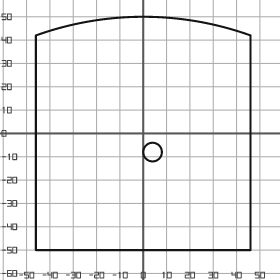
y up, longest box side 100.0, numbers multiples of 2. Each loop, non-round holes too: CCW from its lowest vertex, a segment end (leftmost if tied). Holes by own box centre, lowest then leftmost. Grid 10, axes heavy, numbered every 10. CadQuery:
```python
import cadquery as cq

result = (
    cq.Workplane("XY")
    .moveTo(-46.0, -50.0)
    .lineTo(46.0, -50.0)
    .lineTo(46.0, 42.0)
    .threePointArc((0.0, 50.0), (-46.0, 42.0))
    .close()
    .moveTo(4.0, -8.0)
    .circle(4.0)
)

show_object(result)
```